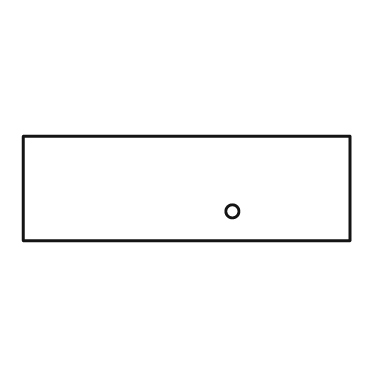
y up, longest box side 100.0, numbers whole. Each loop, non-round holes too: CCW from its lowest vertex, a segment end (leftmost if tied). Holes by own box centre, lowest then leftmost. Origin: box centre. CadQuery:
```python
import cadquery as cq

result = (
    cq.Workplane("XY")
    .moveTo(-50.0, -16.0)
    .lineTo(50.0, -16.0)
    .lineTo(50.0, 16.0)
    .lineTo(-50.0, 16.0)
    .close()
    .moveTo(14.0, -7.0)
    .circle(2.0)
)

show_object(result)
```